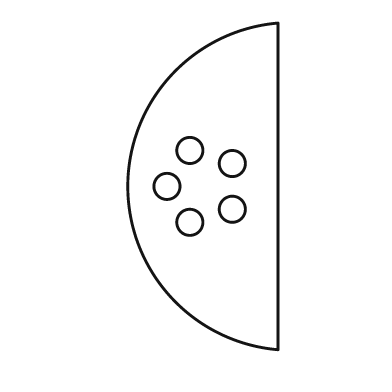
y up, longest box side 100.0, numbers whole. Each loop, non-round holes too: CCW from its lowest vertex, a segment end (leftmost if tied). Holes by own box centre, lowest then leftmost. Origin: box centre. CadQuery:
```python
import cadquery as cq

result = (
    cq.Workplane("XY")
    .moveTo(23.0, -50.0)
    .lineTo(23.0, 50.0)
    .threePointArc((-23.0, 0.0), (23.0, -50.0))
    .close()
    .moveTo(-4.0, -11.0)
    .circle(4.0)
    .moveTo(9.0, -7.0)
    .circle(4.0)
    .moveTo(-11.0, 0.0)
    .circle(4.0)
    .moveTo(9.0, 7.0)
    .circle(4.0)
    .moveTo(-4.0, 11.0)
    .circle(4.0)
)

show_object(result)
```